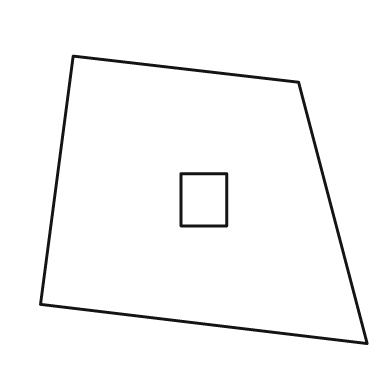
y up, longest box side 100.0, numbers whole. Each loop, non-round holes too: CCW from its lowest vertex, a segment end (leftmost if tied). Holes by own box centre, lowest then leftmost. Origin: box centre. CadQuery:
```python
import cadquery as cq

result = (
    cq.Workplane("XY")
    .moveTo(50.0, -44.0)
    .lineTo(29.0, 36.0)
    .lineTo(-40.0, 44.0)
    .lineTo(-50.0, -32.0)
    .close()
    .moveTo(-7.0, -8.0)
    .lineTo(7.0, -8.0)
    .lineTo(7.0, 8.0)
    .lineTo(-7.0, 8.0)
    .close()
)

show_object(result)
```